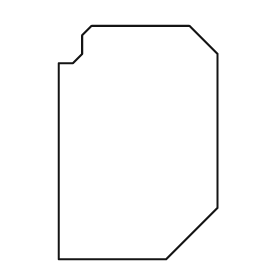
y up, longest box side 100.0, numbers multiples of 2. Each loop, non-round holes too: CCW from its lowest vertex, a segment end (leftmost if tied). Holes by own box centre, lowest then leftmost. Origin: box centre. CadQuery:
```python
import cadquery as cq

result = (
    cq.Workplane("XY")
    .moveTo(-34.0, -50.0)
    .lineTo(12.0, -50.0)
    .lineTo(34.0, -28.0)
    .lineTo(34.0, 38.0)
    .lineTo(22.0, 50.0)
    .lineTo(-20.0, 50.0)
    .lineTo(-24.0, 46.0)
    .lineTo(-24.0, 38.0)
    .lineTo(-28.0, 34.0)
    .lineTo(-34.0, 34.0)
    .close()
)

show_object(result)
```